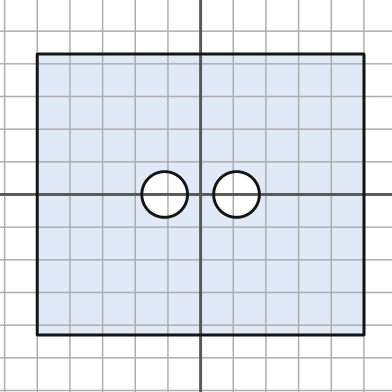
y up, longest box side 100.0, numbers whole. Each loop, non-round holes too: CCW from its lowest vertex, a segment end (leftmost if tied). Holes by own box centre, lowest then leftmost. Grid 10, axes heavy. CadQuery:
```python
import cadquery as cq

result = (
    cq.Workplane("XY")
    .moveTo(-50.0, -43.0)
    .lineTo(50.0, -43.0)
    .lineTo(50.0, 43.0)
    .lineTo(-50.0, 43.0)
    .close()
    .moveTo(-11.0, 0.0)
    .circle(7.0)
    .moveTo(11.0, 0.0)
    .circle(7.0)
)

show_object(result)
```